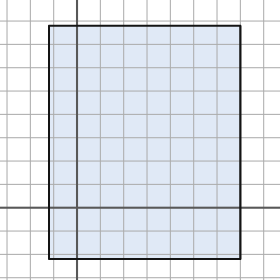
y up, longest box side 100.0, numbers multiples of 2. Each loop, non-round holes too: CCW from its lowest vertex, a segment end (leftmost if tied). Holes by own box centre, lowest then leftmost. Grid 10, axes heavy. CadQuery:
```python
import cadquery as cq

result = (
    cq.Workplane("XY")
    .moveTo(-12.0, -22.0)
    .lineTo(70.0, -22.0)
    .lineTo(70.0, 78.0)
    .lineTo(-12.0, 78.0)
    .close()
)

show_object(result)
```